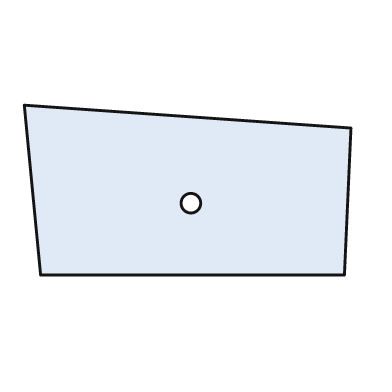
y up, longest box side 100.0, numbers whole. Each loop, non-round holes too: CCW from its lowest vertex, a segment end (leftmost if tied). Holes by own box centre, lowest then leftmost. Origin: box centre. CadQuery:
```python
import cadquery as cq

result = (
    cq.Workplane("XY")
    .moveTo(-45.0, -26.0)
    .lineTo(48.0, -26.0)
    .lineTo(50.0, 19.0)
    .lineTo(-50.0, 26.0)
    .close()
    .moveTo(1.0, -4.0)
    .circle(3.0)
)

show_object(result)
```